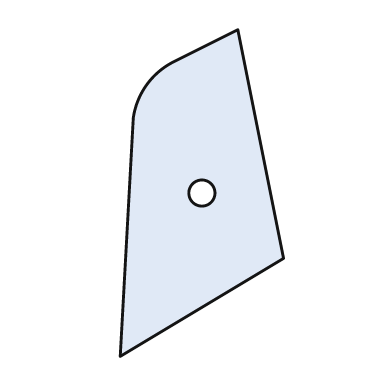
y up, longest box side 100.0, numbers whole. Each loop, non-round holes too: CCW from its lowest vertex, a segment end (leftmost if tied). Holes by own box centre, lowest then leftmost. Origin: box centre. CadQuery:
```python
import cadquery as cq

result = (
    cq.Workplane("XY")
    .moveTo(-25.0, -50.0)
    .lineTo(25.0, -20.0)
    .lineTo(11.0, 50.0)
    .lineTo(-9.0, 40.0)
    .threePointArc((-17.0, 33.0), (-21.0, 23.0))
    .close()
    .moveTo(0.0, 0.0)
    .circle(4.0)
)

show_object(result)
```